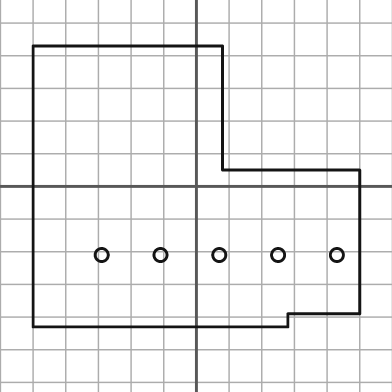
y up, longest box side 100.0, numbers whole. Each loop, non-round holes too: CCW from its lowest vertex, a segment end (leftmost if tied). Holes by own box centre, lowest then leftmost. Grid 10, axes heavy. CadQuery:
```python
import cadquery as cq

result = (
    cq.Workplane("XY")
    .moveTo(-50.0, -43.0)
    .lineTo(28.0, -43.0)
    .lineTo(28.0, -39.0)
    .lineTo(50.0, -39.0)
    .lineTo(50.0, 5.0)
    .lineTo(8.0, 5.0)
    .lineTo(8.0, 43.0)
    .lineTo(-50.0, 43.0)
    .close()
    .moveTo(-29.0, -21.0)
    .circle(2.0)
    .moveTo(-11.0, -21.0)
    .circle(2.0)
    .moveTo(7.0, -21.0)
    .circle(2.0)
    .moveTo(25.0, -21.0)
    .circle(2.0)
    .moveTo(43.0, -21.0)
    .circle(2.0)
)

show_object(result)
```